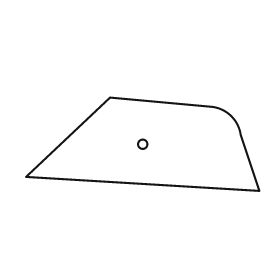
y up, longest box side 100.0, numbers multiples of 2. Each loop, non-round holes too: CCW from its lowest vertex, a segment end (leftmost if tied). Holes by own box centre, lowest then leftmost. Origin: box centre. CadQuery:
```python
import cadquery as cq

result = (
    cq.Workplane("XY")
    .moveTo(50.0, -20.0)
    .lineTo(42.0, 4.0)
    .threePointArc((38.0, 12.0), (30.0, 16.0))
    .lineTo(-14.0, 20.0)
    .lineTo(-50.0, -14.0)
    .close()
    .moveTo(0.0, 0.0)
    .circle(2.0)
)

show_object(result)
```